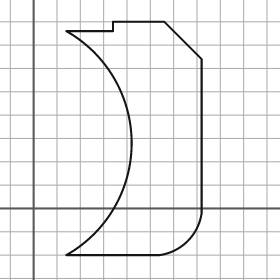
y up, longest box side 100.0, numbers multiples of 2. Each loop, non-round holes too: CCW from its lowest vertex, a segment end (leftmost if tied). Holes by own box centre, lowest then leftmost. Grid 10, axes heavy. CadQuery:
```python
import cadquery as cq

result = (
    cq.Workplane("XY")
    .moveTo(14.0, -20.0)
    .lineTo(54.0, -20.0)
    .threePointArc((66.0, -14.0), (72.0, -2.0))
    .lineTo(72.0, 64.0)
    .lineTo(56.0, 80.0)
    .lineTo(34.0, 80.0)
    .lineTo(34.0, 76.0)
    .lineTo(14.0, 76.0)
    .threePointArc((42.0, 28.0), (14.0, -20.0))
    .close()
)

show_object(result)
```